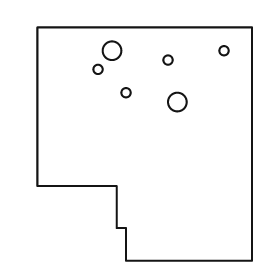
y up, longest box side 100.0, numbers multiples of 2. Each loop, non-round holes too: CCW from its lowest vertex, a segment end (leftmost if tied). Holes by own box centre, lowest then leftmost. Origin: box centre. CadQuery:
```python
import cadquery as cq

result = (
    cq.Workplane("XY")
    .moveTo(-8.0, -50.0)
    .lineTo(46.0, -50.0)
    .lineTo(46.0, 50.0)
    .lineTo(-46.0, 50.0)
    .lineTo(-46.0, -18.0)
    .lineTo(-12.0, -18.0)
    .lineTo(-12.0, -36.0)
    .lineTo(-8.0, -36.0)
    .close()
    .moveTo(14.0, 18.0)
    .circle(4.0)
    .moveTo(-8.0, 22.0)
    .circle(2.0)
    .moveTo(-20.0, 32.0)
    .circle(2.0)
    .moveTo(10.0, 36.0)
    .circle(2.0)
    .moveTo(-14.0, 40.0)
    .circle(4.0)
    .moveTo(34.0, 40.0)
    .circle(2.0)
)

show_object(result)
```